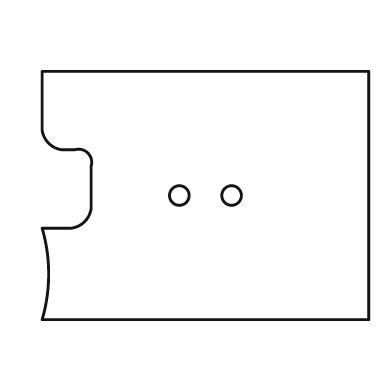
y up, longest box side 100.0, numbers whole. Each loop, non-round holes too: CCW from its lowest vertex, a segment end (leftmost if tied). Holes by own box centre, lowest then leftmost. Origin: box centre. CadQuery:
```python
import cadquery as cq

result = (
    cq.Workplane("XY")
    .moveTo(-50.0, -38.0)
    .lineTo(50.0, -38.0)
    .lineTo(50.0, 38.0)
    .lineTo(-50.0, 38.0)
    .lineTo(-50.0, 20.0)
    .threePointArc((-48.0, 16.0), (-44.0, 14.0))
    .lineTo(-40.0, 14.0)
    .threePointArc((-36.0, 13.0), (-35.0, 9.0))
    .lineTo(-35.0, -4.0)
    .threePointArc((-37.0, -8.0), (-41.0, -10.0))
    .lineTo(-50.0, -10.0)
    .threePointArc((-48.0, -24.0), (-50.0, -38.0))
    .close()
    .moveTo(-8.0, 0.0)
    .circle(3.0)
    .moveTo(8.0, 0.0)
    .circle(3.0)
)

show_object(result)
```